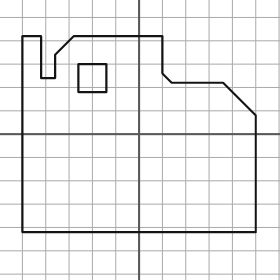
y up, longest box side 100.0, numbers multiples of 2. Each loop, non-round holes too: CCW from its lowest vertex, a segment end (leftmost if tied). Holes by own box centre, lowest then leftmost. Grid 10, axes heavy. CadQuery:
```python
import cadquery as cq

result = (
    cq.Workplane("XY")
    .moveTo(-50.0, -42.0)
    .lineTo(50.0, -42.0)
    .lineTo(50.0, 8.0)
    .lineTo(36.0, 22.0)
    .lineTo(14.0, 22.0)
    .lineTo(10.0, 26.0)
    .lineTo(10.0, 42.0)
    .lineTo(-28.0, 42.0)
    .lineTo(-36.0, 34.0)
    .lineTo(-36.0, 24.0)
    .lineTo(-42.0, 24.0)
    .lineTo(-42.0, 42.0)
    .lineTo(-50.0, 42.0)
    .close()
    .moveTo(-26.0, 18.0)
    .lineTo(-14.0, 18.0)
    .lineTo(-14.0, 30.0)
    .lineTo(-26.0, 30.0)
    .close()
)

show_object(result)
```